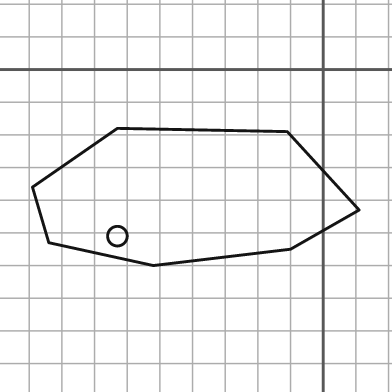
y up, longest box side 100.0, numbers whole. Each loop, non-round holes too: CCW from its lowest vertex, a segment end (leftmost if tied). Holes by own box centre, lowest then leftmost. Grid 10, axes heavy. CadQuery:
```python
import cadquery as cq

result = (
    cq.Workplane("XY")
    .moveTo(-52.0, -60.0)
    .lineTo(-10.0, -55.0)
    .lineTo(11.0, -43.0)
    .lineTo(-11.0, -19.0)
    .lineTo(-63.0, -18.0)
    .lineTo(-89.0, -36.0)
    .lineTo(-84.0, -53.0)
    .close()
    .moveTo(-63.0, -51.0)
    .circle(3.0)
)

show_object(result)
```